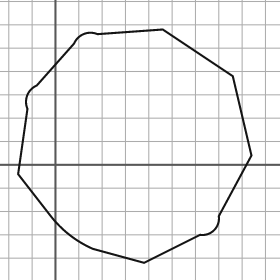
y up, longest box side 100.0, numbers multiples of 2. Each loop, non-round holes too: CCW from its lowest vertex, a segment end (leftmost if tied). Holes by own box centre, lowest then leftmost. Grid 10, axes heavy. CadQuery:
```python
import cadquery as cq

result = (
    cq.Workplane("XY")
    .moveTo(38.0, -42.0)
    .lineTo(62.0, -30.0)
    .threePointArc((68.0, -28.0), (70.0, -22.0))
    .lineTo(84.0, 4.0)
    .lineTo(76.0, 38.0)
    .lineTo(46.0, 58.0)
    .lineTo(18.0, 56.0)
    .threePointArc((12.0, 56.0), (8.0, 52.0))
    .lineTo(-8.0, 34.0)
    .threePointArc((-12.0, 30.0), (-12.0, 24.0))
    .lineTo(-16.0, -4.0)
    .lineTo(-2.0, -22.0)
    .threePointArc((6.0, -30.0), (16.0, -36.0))
    .close()
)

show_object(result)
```